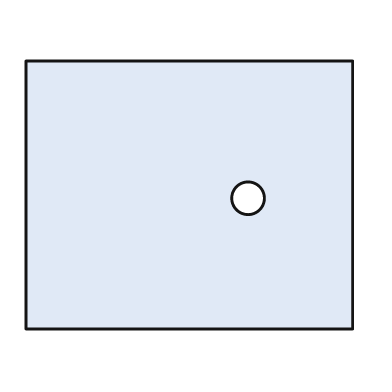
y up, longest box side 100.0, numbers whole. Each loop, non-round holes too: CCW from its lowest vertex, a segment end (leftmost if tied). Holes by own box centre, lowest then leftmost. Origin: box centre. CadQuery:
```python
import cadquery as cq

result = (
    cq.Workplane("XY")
    .moveTo(-50.0, -41.0)
    .lineTo(50.0, -41.0)
    .lineTo(50.0, 41.0)
    .lineTo(-50.0, 41.0)
    .close()
    .moveTo(18.0, -1.0)
    .circle(5.0)
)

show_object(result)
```